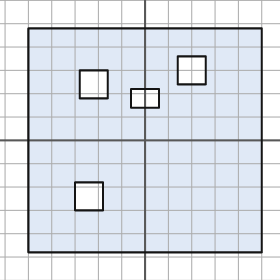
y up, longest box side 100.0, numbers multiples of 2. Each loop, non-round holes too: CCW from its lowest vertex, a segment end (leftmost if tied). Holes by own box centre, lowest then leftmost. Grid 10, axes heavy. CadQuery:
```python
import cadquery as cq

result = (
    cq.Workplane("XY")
    .moveTo(-50.0, -48.0)
    .lineTo(50.0, -48.0)
    .lineTo(50.0, 48.0)
    .lineTo(-50.0, 48.0)
    .close()
    .moveTo(-30.0, -30.0)
    .lineTo(-18.0, -30.0)
    .lineTo(-18.0, -18.0)
    .lineTo(-30.0, -18.0)
    .close()
    .moveTo(-6.0, 14.0)
    .lineTo(6.0, 14.0)
    .lineTo(6.0, 22.0)
    .lineTo(-6.0, 22.0)
    .close()
    .moveTo(-28.0, 18.0)
    .lineTo(-16.0, 18.0)
    .lineTo(-16.0, 30.0)
    .lineTo(-28.0, 30.0)
    .close()
    .moveTo(14.0, 24.0)
    .lineTo(26.0, 24.0)
    .lineTo(26.0, 36.0)
    .lineTo(14.0, 36.0)
    .close()
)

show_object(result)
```